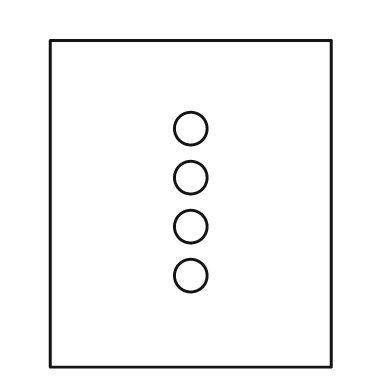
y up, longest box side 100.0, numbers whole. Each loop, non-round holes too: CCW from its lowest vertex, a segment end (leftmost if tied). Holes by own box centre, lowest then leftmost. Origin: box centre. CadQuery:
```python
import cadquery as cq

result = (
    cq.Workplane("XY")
    .moveTo(-43.0, -50.0)
    .lineTo(43.0, -50.0)
    .lineTo(43.0, 50.0)
    .lineTo(-43.0, 50.0)
    .close()
    .moveTo(0.0, -22.0)
    .circle(5.0)
    .moveTo(0.0, -7.0)
    .circle(5.0)
    .moveTo(0.0, 8.0)
    .circle(5.0)
    .moveTo(0.0, 23.0)
    .circle(5.0)
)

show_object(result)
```